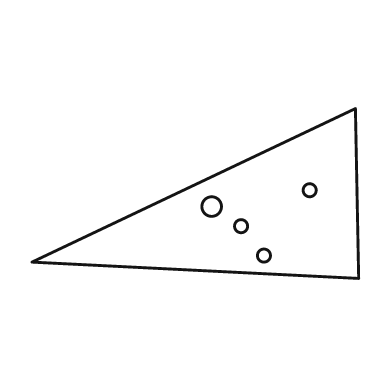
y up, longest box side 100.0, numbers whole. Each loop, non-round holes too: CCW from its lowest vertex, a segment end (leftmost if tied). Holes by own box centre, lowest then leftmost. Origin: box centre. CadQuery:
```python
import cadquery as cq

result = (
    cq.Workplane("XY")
    .moveTo(50.0, -26.0)
    .lineTo(49.0, 26.0)
    .lineTo(-50.0, -21.0)
    .close()
    .moveTo(21.0, -19.0)
    .circle(2.0)
    .moveTo(14.0, -10.0)
    .circle(2.0)
    .moveTo(5.0, -4.0)
    .circle(3.0)
    .moveTo(35.0, 1.0)
    .circle(2.0)
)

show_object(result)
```